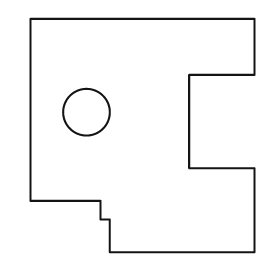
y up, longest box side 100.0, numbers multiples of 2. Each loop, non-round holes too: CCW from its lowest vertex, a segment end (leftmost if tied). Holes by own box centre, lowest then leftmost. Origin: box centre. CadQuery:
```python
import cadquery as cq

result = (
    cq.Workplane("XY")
    .moveTo(-14.0, -50.0)
    .lineTo(48.0, -50.0)
    .lineTo(48.0, -14.0)
    .lineTo(20.0, -14.0)
    .lineTo(20.0, 26.0)
    .lineTo(48.0, 26.0)
    .lineTo(48.0, 50.0)
    .lineTo(-48.0, 50.0)
    .lineTo(-48.0, -28.0)
    .lineTo(-18.0, -28.0)
    .lineTo(-18.0, -36.0)
    .lineTo(-14.0, -36.0)
    .close()
    .moveTo(-24.0, 10.0)
    .circle(10.0)
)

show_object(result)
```